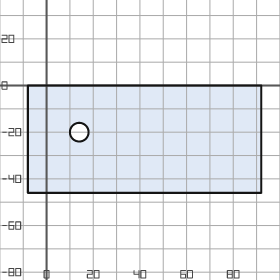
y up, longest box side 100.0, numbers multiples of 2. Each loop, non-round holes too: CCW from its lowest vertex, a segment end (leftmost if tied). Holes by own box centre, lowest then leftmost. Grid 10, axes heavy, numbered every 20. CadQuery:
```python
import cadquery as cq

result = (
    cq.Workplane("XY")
    .moveTo(-8.0, -46.0)
    .lineTo(92.0, -46.0)
    .lineTo(92.0, 0.0)
    .lineTo(-8.0, 0.0)
    .close()
    .moveTo(14.0, -20.0)
    .circle(4.0)
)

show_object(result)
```